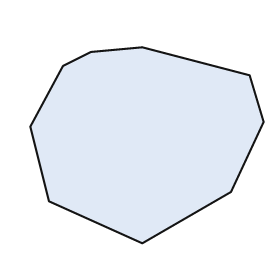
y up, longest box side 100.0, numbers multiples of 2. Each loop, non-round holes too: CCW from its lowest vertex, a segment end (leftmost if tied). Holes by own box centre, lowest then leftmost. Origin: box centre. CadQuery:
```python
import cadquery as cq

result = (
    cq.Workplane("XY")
    .moveTo(-2.0, -42.0)
    .lineTo(36.0, -20.0)
    .lineTo(50.0, 10.0)
    .lineTo(44.0, 30.0)
    .lineTo(-2.0, 42.0)
    .lineTo(-24.0, 40.0)
    .lineTo(-36.0, 34.0)
    .lineTo(-50.0, 8.0)
    .lineTo(-42.0, -24.0)
    .close()
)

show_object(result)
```